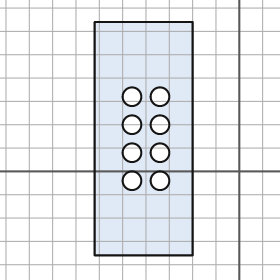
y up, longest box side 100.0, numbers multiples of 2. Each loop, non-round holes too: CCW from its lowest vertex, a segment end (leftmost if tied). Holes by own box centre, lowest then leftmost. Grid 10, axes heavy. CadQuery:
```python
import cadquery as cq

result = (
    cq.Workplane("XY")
    .moveTo(-62.0, -36.0)
    .lineTo(-20.0, -36.0)
    .lineTo(-20.0, 64.0)
    .lineTo(-62.0, 64.0)
    .close()
    .moveTo(-46.0, -4.0)
    .circle(4.0)
    .moveTo(-34.0, -4.0)
    .circle(4.0)
    .moveTo(-46.0, 8.0)
    .circle(4.0)
    .moveTo(-34.0, 8.0)
    .circle(4.0)
    .moveTo(-46.0, 20.0)
    .circle(4.0)
    .moveTo(-34.0, 20.0)
    .circle(4.0)
    .moveTo(-46.0, 32.0)
    .circle(4.0)
    .moveTo(-34.0, 32.0)
    .circle(4.0)
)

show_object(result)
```